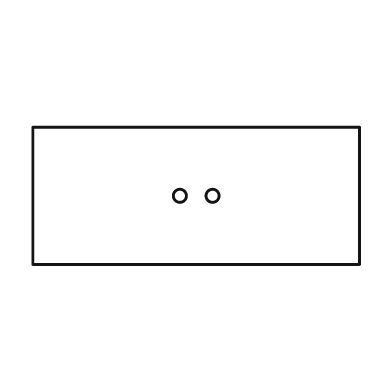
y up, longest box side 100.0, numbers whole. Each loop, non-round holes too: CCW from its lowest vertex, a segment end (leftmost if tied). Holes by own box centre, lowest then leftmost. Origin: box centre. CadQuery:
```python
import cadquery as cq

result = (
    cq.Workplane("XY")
    .moveTo(-50.0, -21.0)
    .lineTo(50.0, -21.0)
    .lineTo(50.0, 21.0)
    .lineTo(-50.0, 21.0)
    .close()
    .moveTo(-5.0, 0.0)
    .circle(2.0)
    .moveTo(5.0, 0.0)
    .circle(2.0)
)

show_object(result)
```